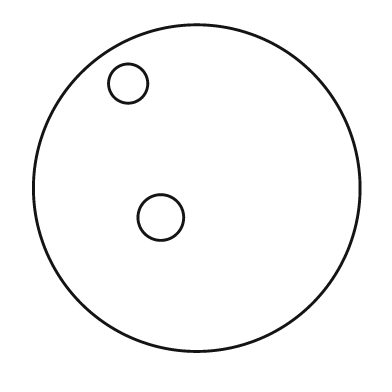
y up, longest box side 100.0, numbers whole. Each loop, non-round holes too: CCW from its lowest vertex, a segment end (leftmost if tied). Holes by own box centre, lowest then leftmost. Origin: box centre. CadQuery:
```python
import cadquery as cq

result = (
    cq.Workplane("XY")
    .moveTo(0.0, 0.0)
    .circle(50.0)
    .moveTo(-11.0, -9.0)
    .circle(7.0)
    .moveTo(-21.0, 32.0)
    .circle(6.0)
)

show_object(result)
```